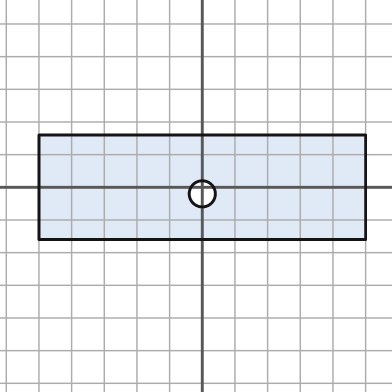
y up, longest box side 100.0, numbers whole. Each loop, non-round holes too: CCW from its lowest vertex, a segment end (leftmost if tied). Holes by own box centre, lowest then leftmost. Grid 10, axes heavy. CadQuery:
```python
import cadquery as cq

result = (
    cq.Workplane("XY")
    .moveTo(-50.0, -16.0)
    .lineTo(50.0, -16.0)
    .lineTo(50.0, 16.0)
    .lineTo(-50.0, 16.0)
    .close()
    .moveTo(0.0, -2.0)
    .circle(4.0)
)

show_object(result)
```